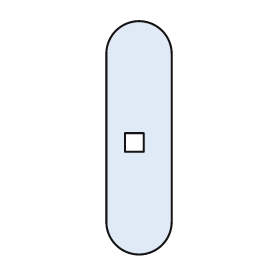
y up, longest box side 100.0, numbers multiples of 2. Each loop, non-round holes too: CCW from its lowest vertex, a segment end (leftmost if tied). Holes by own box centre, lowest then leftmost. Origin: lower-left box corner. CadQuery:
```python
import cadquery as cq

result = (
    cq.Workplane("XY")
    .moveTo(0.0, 14.0)
    .threePointArc((14.0, 0.0), (28.0, 14.0))
    .lineTo(28.0, 86.0)
    .threePointArc((14.0, 100.0), (0.0, 86.0))
    .close()
    .moveTo(8.0, 44.0)
    .lineTo(16.0, 44.0)
    .lineTo(16.0, 52.0)
    .lineTo(8.0, 52.0)
    .close()
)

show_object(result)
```